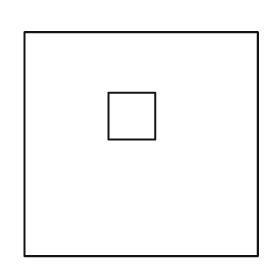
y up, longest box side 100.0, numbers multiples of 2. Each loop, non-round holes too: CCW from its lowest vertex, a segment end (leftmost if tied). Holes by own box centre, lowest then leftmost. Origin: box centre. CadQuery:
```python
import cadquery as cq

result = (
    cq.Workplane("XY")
    .moveTo(-50.0, -48.0)
    .lineTo(50.0, -48.0)
    .lineTo(50.0, 48.0)
    .lineTo(-50.0, 48.0)
    .close()
    .moveTo(-14.0, 2.0)
    .lineTo(6.0, 2.0)
    .lineTo(6.0, 22.0)
    .lineTo(-14.0, 22.0)
    .close()
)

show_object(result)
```